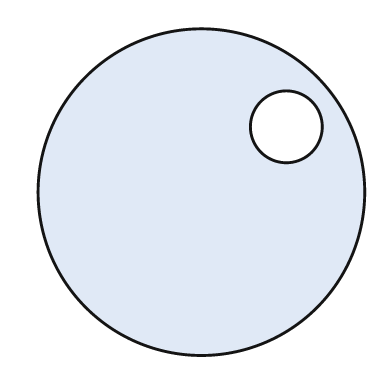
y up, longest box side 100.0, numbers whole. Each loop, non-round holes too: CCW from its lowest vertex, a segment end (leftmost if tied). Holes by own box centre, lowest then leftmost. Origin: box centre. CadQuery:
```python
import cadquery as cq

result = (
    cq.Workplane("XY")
    .moveTo(0.0, 0.0)
    .circle(50.0)
    .moveTo(26.0, 20.0)
    .circle(11.0)
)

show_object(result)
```